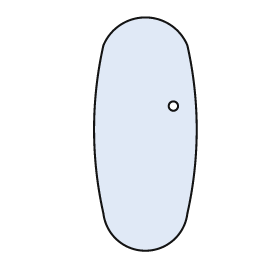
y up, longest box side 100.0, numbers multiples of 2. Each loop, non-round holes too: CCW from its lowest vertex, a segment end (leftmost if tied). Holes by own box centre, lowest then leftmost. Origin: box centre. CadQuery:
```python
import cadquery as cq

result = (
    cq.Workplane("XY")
    .moveTo(-18.0, -34.0)
    .threePointArc((0.0, -50.0), (18.0, -34.0))
    .threePointArc((22.0, 2.0), (18.0, 38.0))
    .threePointArc((0.0, 50.0), (-18.0, 38.0))
    .threePointArc((-22.0, 2.0), (-18.0, -34.0))
    .close()
    .moveTo(12.0, 12.0)
    .circle(2.0)
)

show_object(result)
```